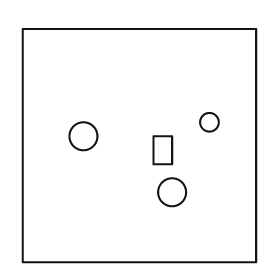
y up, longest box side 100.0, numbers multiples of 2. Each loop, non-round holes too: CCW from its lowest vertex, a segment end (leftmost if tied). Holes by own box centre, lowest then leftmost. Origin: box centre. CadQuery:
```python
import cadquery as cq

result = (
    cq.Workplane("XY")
    .moveTo(-50.0, -50.0)
    .lineTo(50.0, -50.0)
    .lineTo(50.0, 50.0)
    .lineTo(-50.0, 50.0)
    .close()
    .moveTo(14.0, -20.0)
    .circle(6.0)
    .moveTo(6.0, -8.0)
    .lineTo(14.0, -8.0)
    .lineTo(14.0, 4.0)
    .lineTo(6.0, 4.0)
    .close()
    .moveTo(-24.0, 4.0)
    .circle(6.0)
    .moveTo(30.0, 10.0)
    .circle(4.0)
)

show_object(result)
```